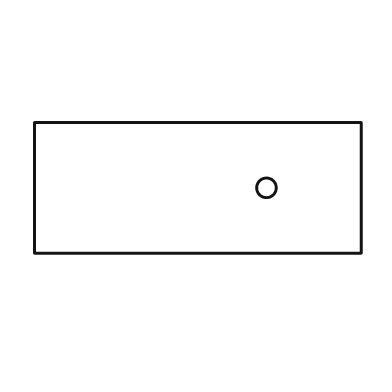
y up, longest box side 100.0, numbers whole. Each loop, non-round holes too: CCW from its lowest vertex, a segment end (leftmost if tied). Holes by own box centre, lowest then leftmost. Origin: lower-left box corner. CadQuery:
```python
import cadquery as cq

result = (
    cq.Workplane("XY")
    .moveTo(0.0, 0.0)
    .lineTo(100.0, 0.0)
    .lineTo(100.0, 40.0)
    .lineTo(0.0, 40.0)
    .close()
    .moveTo(71.0, 20.0)
    .circle(3.0)
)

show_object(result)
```